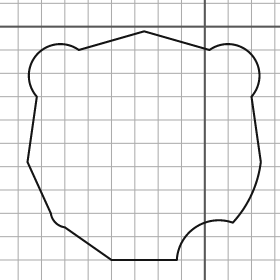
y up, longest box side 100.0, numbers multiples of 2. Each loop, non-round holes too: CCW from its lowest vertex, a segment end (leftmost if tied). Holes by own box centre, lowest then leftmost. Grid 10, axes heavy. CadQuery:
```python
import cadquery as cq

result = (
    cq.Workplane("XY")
    .moveTo(-40.0, -100.0)
    .lineTo(-12.0, -100.0)
    .threePointArc((-4.0, -86.0), (12.0, -84.0))
    .threePointArc((20.0, -72.0), (24.0, -58.0))
    .lineTo(20.0, -30.0)
    .threePointArc((20.0, -12.0), (2.0, -10.0))
    .lineTo(-26.0, -2.0)
    .lineTo(-54.0, -10.0)
    .threePointArc((-72.0, -12.0), (-72.0, -30.0))
    .lineTo(-76.0, -58.0)
    .lineTo(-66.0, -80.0)
    .threePointArc((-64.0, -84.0), (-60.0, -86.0))
    .close()
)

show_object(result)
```